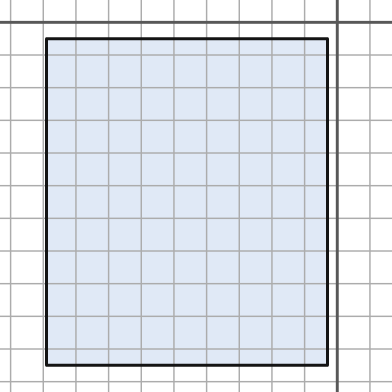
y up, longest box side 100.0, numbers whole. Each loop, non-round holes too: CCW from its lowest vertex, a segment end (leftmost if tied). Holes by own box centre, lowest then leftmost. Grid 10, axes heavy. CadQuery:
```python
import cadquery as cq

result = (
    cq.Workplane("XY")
    .moveTo(-89.0, -105.0)
    .lineTo(-3.0, -105.0)
    .lineTo(-3.0, -5.0)
    .lineTo(-89.0, -5.0)
    .close()
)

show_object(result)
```